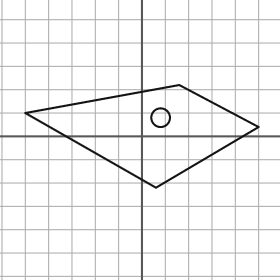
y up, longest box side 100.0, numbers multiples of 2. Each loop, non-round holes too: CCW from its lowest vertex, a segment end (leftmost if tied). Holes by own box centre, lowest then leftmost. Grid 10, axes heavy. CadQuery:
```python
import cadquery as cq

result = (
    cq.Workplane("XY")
    .moveTo(6.0, -22.0)
    .lineTo(50.0, 4.0)
    .lineTo(16.0, 22.0)
    .lineTo(-50.0, 10.0)
    .close()
    .moveTo(8.0, 8.0)
    .circle(4.0)
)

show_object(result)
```